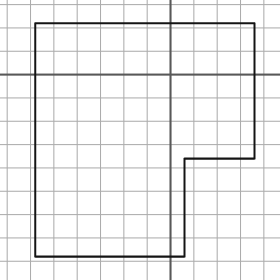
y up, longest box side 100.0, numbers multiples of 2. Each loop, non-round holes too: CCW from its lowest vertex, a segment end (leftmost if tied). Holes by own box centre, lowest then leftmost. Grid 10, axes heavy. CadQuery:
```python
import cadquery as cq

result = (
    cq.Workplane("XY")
    .moveTo(-58.0, -78.0)
    .lineTo(6.0, -78.0)
    .lineTo(6.0, -36.0)
    .lineTo(36.0, -36.0)
    .lineTo(36.0, 22.0)
    .lineTo(-58.0, 22.0)
    .close()
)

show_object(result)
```